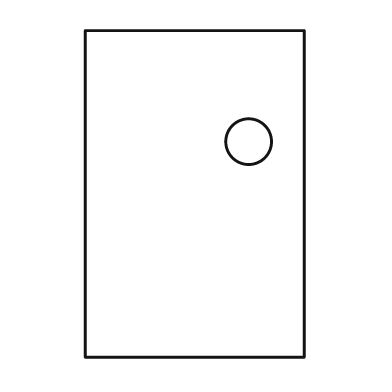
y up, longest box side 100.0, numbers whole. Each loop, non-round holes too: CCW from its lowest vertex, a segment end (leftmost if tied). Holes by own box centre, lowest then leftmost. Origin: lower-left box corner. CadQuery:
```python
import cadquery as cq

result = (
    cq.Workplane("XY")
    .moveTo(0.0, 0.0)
    .lineTo(67.0, 0.0)
    .lineTo(67.0, 100.0)
    .lineTo(0.0, 100.0)
    .close()
    .moveTo(50.0, 66.0)
    .circle(7.0)
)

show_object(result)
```